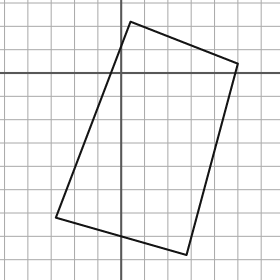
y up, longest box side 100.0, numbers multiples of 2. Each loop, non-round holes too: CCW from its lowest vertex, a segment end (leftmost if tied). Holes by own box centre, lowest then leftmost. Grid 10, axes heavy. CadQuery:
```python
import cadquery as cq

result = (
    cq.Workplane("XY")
    .moveTo(28.0, -78.0)
    .lineTo(50.0, 4.0)
    .lineTo(4.0, 22.0)
    .lineTo(-28.0, -62.0)
    .close()
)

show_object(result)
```